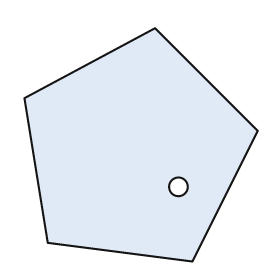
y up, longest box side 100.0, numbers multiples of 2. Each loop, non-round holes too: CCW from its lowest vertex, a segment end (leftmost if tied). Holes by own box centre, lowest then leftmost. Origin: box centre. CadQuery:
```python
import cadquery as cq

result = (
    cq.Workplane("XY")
    .moveTo(22.0, -50.0)
    .lineTo(50.0, 6.0)
    .lineTo(6.0, 50.0)
    .lineTo(-50.0, 20.0)
    .lineTo(-40.0, -42.0)
    .close()
    .moveTo(16.0, -18.0)
    .circle(4.0)
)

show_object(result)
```